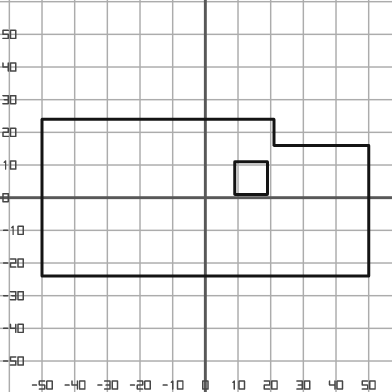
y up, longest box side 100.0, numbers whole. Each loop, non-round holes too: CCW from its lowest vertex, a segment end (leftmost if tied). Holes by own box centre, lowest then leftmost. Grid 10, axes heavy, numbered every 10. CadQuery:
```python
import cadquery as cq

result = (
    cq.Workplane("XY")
    .moveTo(-50.0, -24.0)
    .lineTo(50.0, -24.0)
    .lineTo(50.0, 16.0)
    .lineTo(21.0, 16.0)
    .lineTo(21.0, 24.0)
    .lineTo(-50.0, 24.0)
    .close()
    .moveTo(9.0, 1.0)
    .lineTo(19.0, 1.0)
    .lineTo(19.0, 11.0)
    .lineTo(9.0, 11.0)
    .close()
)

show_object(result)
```